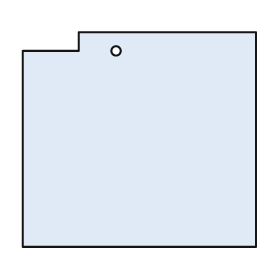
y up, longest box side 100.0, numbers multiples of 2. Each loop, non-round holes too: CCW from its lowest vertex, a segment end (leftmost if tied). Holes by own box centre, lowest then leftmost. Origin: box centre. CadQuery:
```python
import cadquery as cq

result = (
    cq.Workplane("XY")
    .moveTo(-50.0, -46.0)
    .lineTo(50.0, -46.0)
    .lineTo(50.0, 46.0)
    .lineTo(-26.0, 46.0)
    .lineTo(-26.0, 38.0)
    .lineTo(-50.0, 38.0)
    .close()
    .moveTo(-10.0, 38.0)
    .circle(2.0)
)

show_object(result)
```